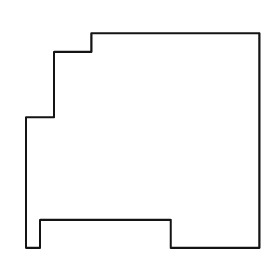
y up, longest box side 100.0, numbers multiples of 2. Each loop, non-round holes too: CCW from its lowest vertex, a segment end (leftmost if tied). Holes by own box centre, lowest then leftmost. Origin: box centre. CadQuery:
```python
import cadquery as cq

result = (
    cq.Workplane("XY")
    .moveTo(-50.0, -46.0)
    .lineTo(-44.0, -46.0)
    .lineTo(-44.0, -34.0)
    .lineTo(12.0, -34.0)
    .lineTo(12.0, -46.0)
    .lineTo(50.0, -46.0)
    .lineTo(50.0, 46.0)
    .lineTo(-22.0, 46.0)
    .lineTo(-22.0, 38.0)
    .lineTo(-38.0, 38.0)
    .lineTo(-38.0, 10.0)
    .lineTo(-50.0, 10.0)
    .close()
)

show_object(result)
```